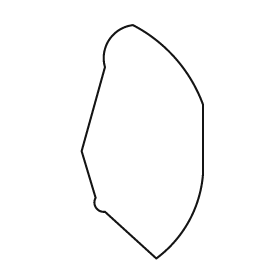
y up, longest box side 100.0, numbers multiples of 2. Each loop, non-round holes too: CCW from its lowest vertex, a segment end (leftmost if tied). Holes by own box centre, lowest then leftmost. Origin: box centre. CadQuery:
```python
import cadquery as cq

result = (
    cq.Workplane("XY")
    .moveTo(6.0, -50.0)
    .threePointArc((20.0, -34.0), (26.0, -14.0))
    .lineTo(26.0, 16.0)
    .threePointArc((14.0, 36.0), (-4.0, 50.0))
    .threePointArc((-14.0, 44.0), (-16.0, 32.0))
    .lineTo(-26.0, -4.0)
    .lineTo(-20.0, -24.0)
    .threePointArc((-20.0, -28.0), (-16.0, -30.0))
    .close()
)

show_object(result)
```